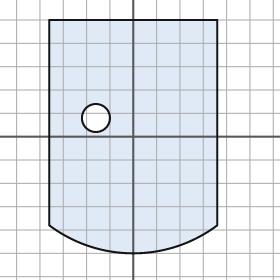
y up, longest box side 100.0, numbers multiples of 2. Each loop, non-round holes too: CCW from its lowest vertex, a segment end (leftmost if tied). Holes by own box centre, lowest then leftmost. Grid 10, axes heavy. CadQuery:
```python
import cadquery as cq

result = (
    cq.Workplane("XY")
    .moveTo(-36.0, -38.0)
    .threePointArc((0.0, -50.0), (36.0, -38.0))
    .lineTo(36.0, 50.0)
    .lineTo(-36.0, 50.0)
    .close()
    .moveTo(-16.0, 8.0)
    .circle(6.0)
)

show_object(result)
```